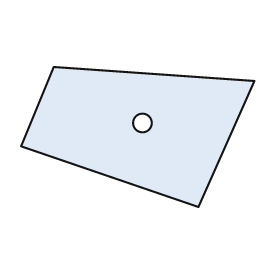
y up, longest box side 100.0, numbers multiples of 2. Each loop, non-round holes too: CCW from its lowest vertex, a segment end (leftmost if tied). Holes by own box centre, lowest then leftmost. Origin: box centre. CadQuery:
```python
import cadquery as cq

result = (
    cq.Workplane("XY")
    .moveTo(26.0, -30.0)
    .lineTo(50.0, 24.0)
    .lineTo(-36.0, 30.0)
    .lineTo(-50.0, -4.0)
    .close()
    .moveTo(2.0, 6.0)
    .circle(4.0)
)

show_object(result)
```